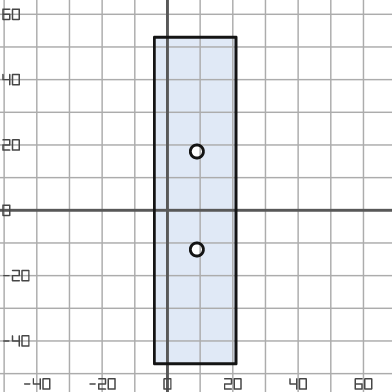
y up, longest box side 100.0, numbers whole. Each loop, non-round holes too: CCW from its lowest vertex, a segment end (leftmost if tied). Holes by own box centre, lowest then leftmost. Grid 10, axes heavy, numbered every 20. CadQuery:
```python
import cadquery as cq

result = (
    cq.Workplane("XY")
    .moveTo(-4.0, -47.0)
    .lineTo(21.0, -47.0)
    .lineTo(21.0, 53.0)
    .lineTo(-4.0, 53.0)
    .close()
    .moveTo(9.0, -12.0)
    .circle(2.0)
    .moveTo(9.0, 18.0)
    .circle(2.0)
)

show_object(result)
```